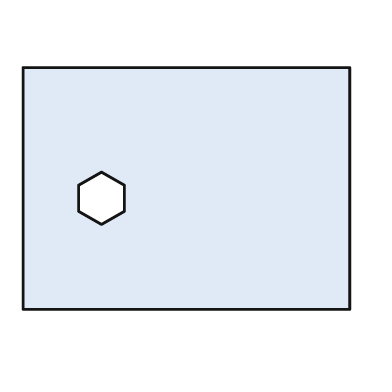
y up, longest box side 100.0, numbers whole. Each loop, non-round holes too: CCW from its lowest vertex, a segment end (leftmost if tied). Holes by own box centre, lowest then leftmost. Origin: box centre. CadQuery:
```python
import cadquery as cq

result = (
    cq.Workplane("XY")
    .moveTo(-50.0, -37.0)
    .lineTo(50.0, -37.0)
    .lineTo(50.0, 37.0)
    .lineTo(-50.0, 37.0)
    .close()
    .moveTo(-26.0, -11.0)
    .lineTo(-19.0, -7.0)
    .lineTo(-19.0, 1.0)
    .lineTo(-26.0, 5.0)
    .lineTo(-33.0, 1.0)
    .lineTo(-33.0, -7.0)
    .close()
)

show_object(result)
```